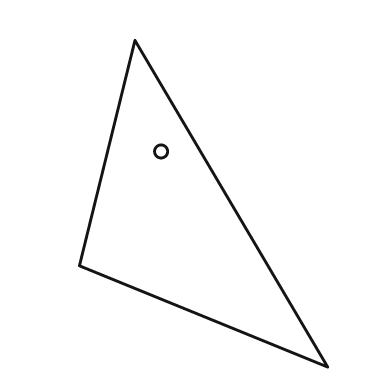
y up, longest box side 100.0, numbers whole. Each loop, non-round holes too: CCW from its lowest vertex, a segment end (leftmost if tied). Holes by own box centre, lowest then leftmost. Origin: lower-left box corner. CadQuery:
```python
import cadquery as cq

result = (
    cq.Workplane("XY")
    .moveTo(76.0, 0.0)
    .lineTo(17.0, 100.0)
    .lineTo(0.0, 31.0)
    .close()
    .moveTo(25.0, 66.0)
    .circle(2.0)
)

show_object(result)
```